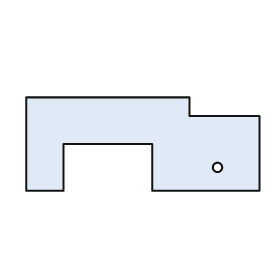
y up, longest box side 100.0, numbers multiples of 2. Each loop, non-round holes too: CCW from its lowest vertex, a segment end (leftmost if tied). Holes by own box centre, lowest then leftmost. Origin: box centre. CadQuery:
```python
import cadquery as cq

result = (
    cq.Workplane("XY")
    .moveTo(-50.0, -20.0)
    .lineTo(-34.0, -20.0)
    .lineTo(-34.0, 0.0)
    .lineTo(4.0, 0.0)
    .lineTo(4.0, -20.0)
    .lineTo(50.0, -20.0)
    .lineTo(50.0, 12.0)
    .lineTo(20.0, 12.0)
    .lineTo(20.0, 20.0)
    .lineTo(-50.0, 20.0)
    .close()
    .moveTo(32.0, -10.0)
    .circle(2.0)
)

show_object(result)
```